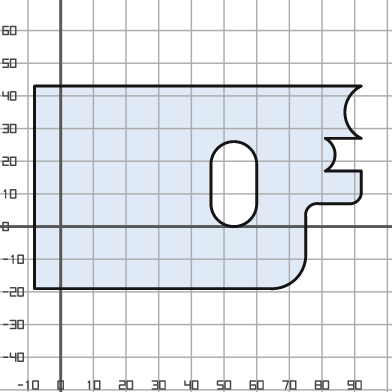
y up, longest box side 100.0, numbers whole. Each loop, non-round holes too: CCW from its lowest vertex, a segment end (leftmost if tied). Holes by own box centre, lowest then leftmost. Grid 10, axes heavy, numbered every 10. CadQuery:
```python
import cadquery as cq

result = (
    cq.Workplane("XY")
    .moveTo(-8.0, -19.0)
    .lineTo(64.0, -19.0)
    .threePointArc((72.0, -16.0), (75.0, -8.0))
    .lineTo(75.0, 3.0)
    .threePointArc((76.0, 6.0), (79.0, 7.0))
    .lineTo(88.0, 7.0)
    .threePointArc((91.0, 8.0), (92.0, 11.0))
    .lineTo(92.0, 17.0)
    .lineTo(81.0, 17.0)
    .threePointArc((84.0, 22.0), (81.0, 27.0))
    .lineTo(92.0, 27.0)
    .threePointArc((87.0, 35.0), (92.0, 43.0))
    .lineTo(-8.0, 43.0)
    .close()
    .moveTo(46.0, 7.0)
    .threePointArc((53.0, 0.0), (60.0, 7.0))
    .lineTo(60.0, 19.0)
    .threePointArc((53.0, 26.0), (46.0, 19.0))
    .close()
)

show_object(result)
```